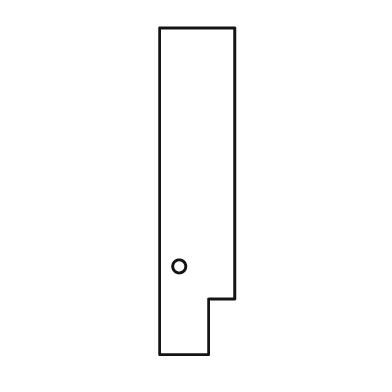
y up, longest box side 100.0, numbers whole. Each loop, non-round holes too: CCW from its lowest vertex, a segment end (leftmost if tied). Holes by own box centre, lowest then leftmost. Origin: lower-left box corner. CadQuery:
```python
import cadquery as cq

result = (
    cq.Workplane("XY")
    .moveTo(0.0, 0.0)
    .lineTo(15.0, 0.0)
    .lineTo(15.0, 17.0)
    .lineTo(23.0, 17.0)
    .lineTo(23.0, 100.0)
    .lineTo(0.0, 100.0)
    .close()
    .moveTo(6.0, 27.0)
    .circle(2.0)
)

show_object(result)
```